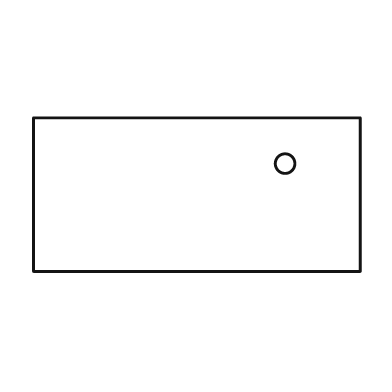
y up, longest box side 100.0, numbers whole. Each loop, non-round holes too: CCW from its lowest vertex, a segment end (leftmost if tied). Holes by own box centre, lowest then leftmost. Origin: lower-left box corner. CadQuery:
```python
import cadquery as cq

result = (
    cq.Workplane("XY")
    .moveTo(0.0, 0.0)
    .lineTo(100.0, 0.0)
    .lineTo(100.0, 47.0)
    .lineTo(0.0, 47.0)
    .close()
    .moveTo(77.0, 33.0)
    .circle(3.0)
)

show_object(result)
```